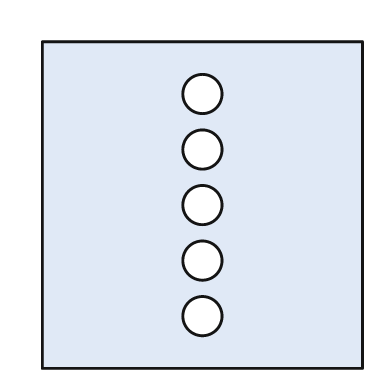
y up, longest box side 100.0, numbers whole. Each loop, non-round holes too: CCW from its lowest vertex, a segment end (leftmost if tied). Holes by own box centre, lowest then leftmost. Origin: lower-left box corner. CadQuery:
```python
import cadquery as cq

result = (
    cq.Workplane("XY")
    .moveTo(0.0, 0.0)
    .lineTo(98.0, 0.0)
    .lineTo(98.0, 100.0)
    .lineTo(0.0, 100.0)
    .close()
    .moveTo(49.0, 16.0)
    .circle(6.0)
    .moveTo(49.0, 33.0)
    .circle(6.0)
    .moveTo(49.0, 50.0)
    .circle(6.0)
    .moveTo(49.0, 67.0)
    .circle(6.0)
    .moveTo(49.0, 84.0)
    .circle(6.0)
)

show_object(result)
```